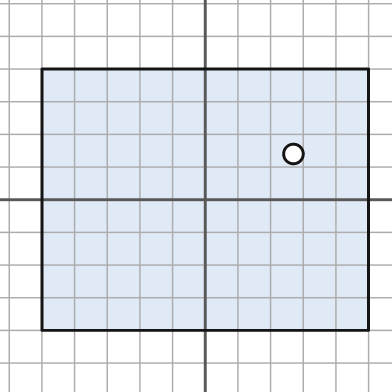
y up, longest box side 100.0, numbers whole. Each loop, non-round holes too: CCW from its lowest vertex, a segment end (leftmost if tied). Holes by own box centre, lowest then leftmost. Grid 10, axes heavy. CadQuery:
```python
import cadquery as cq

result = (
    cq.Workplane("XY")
    .moveTo(-50.0, -40.0)
    .lineTo(50.0, -40.0)
    .lineTo(50.0, 40.0)
    .lineTo(-50.0, 40.0)
    .close()
    .moveTo(27.0, 14.0)
    .circle(3.0)
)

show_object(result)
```